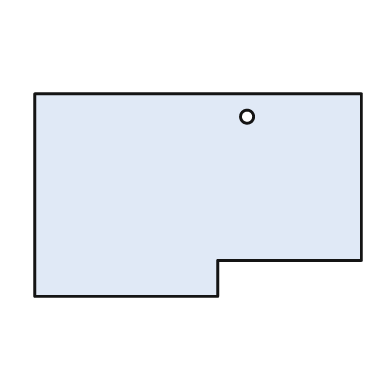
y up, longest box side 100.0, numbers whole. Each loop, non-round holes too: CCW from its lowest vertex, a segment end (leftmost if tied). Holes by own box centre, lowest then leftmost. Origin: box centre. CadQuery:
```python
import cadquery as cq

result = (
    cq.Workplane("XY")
    .moveTo(-50.0, -31.0)
    .lineTo(6.0, -31.0)
    .lineTo(6.0, -20.0)
    .lineTo(50.0, -20.0)
    .lineTo(50.0, 31.0)
    .lineTo(-50.0, 31.0)
    .close()
    .moveTo(15.0, 24.0)
    .circle(2.0)
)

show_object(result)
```